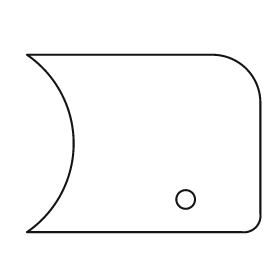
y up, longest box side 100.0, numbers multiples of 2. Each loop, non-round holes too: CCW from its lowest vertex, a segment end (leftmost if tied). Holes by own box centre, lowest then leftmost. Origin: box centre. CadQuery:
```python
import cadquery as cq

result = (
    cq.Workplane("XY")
    .moveTo(-50.0, -38.0)
    .lineTo(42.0, -38.0)
    .threePointArc((48.0, -36.0), (50.0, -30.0))
    .lineTo(50.0, 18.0)
    .threePointArc((44.0, 32.0), (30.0, 38.0))
    .lineTo(-50.0, 38.0)
    .threePointArc((-30.0, 0.0), (-50.0, -38.0))
    .close()
    .moveTo(18.0, -24.0)
    .circle(4.0)
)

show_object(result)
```